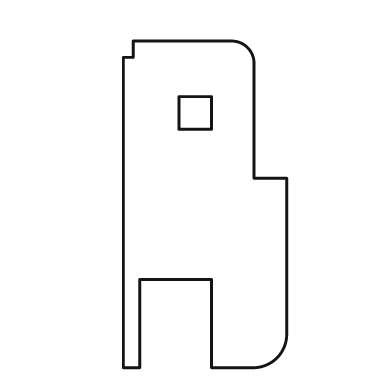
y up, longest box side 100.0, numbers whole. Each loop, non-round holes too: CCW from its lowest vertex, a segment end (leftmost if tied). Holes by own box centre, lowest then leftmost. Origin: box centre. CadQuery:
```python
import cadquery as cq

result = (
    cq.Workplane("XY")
    .moveTo(-25.0, -50.0)
    .lineTo(-20.0, -50.0)
    .lineTo(-20.0, -23.0)
    .lineTo(2.0, -23.0)
    .lineTo(2.0, -50.0)
    .lineTo(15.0, -50.0)
    .threePointArc((22.0, -47.0), (25.0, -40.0))
    .lineTo(25.0, 8.0)
    .lineTo(15.0, 8.0)
    .lineTo(15.0, 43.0)
    .threePointArc((13.0, 48.0), (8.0, 50.0))
    .lineTo(-22.0, 50.0)
    .lineTo(-22.0, 45.0)
    .lineTo(-25.0, 45.0)
    .close()
    .moveTo(-8.0, 23.0)
    .lineTo(2.0, 23.0)
    .lineTo(2.0, 33.0)
    .lineTo(-8.0, 33.0)
    .close()
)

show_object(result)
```